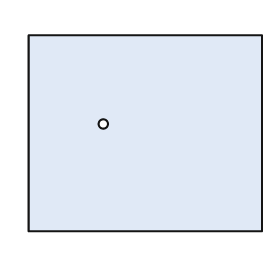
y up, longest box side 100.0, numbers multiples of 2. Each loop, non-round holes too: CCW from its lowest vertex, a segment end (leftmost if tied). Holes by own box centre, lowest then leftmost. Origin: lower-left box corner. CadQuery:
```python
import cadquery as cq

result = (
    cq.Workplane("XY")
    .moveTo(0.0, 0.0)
    .lineTo(100.0, 0.0)
    .lineTo(100.0, 84.0)
    .lineTo(0.0, 84.0)
    .close()
    .moveTo(32.0, 46.0)
    .circle(2.0)
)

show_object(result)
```